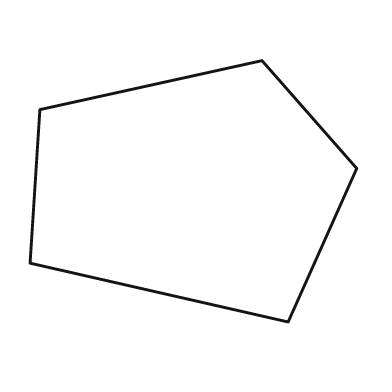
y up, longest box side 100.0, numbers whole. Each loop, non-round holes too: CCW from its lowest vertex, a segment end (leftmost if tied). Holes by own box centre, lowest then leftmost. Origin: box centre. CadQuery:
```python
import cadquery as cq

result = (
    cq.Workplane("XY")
    .moveTo(29.0, -40.0)
    .lineTo(50.0, 7.0)
    .lineTo(21.0, 40.0)
    .lineTo(-47.0, 25.0)
    .lineTo(-50.0, -22.0)
    .close()
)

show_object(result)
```